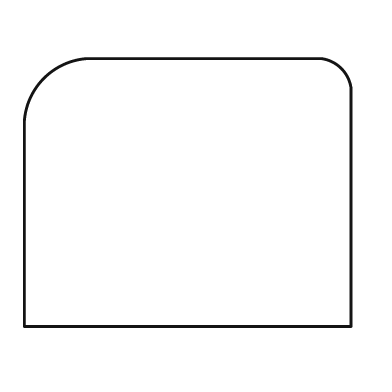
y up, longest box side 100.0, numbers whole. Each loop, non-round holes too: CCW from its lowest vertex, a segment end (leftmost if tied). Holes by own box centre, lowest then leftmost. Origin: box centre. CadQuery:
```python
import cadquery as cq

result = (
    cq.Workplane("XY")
    .moveTo(-50.0, -41.0)
    .lineTo(50.0, -41.0)
    .lineTo(50.0, 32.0)
    .threePointArc((47.0, 38.0), (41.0, 41.0))
    .lineTo(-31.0, 41.0)
    .threePointArc((-44.0, 35.0), (-50.0, 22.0))
    .close()
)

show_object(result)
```